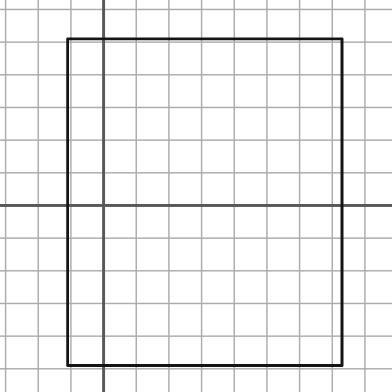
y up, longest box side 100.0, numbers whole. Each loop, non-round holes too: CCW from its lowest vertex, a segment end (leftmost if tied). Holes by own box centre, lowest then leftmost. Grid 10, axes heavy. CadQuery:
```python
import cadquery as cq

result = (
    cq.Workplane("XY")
    .moveTo(-11.0, -49.0)
    .lineTo(73.0, -49.0)
    .lineTo(73.0, 51.0)
    .lineTo(-11.0, 51.0)
    .close()
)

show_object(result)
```